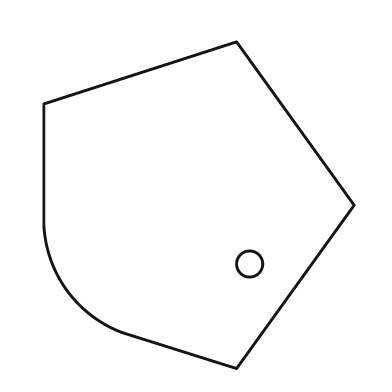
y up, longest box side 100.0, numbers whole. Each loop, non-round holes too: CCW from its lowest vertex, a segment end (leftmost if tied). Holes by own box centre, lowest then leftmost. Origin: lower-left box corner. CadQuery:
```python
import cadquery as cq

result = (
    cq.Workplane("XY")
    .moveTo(59.0, 0.0)
    .lineTo(95.0, 50.0)
    .lineTo(59.0, 100.0)
    .lineTo(0.0, 81.0)
    .lineTo(0.0, 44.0)
    .threePointArc((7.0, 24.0), (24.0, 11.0))
    .close()
    .moveTo(63.0, 32.0)
    .circle(4.0)
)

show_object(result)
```